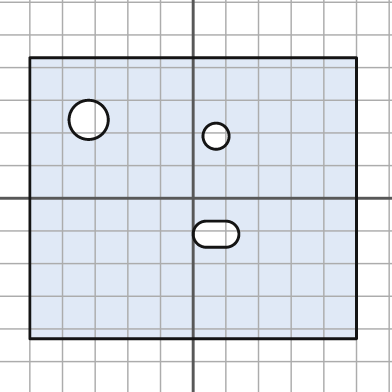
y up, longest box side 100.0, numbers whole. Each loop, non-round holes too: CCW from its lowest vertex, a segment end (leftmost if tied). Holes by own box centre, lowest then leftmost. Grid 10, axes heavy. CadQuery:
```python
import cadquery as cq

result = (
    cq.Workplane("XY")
    .moveTo(-50.0, -43.0)
    .lineTo(50.0, -43.0)
    .lineTo(50.0, 43.0)
    .lineTo(-50.0, 43.0)
    .close()
    .moveTo(4.0, -15.0)
    .lineTo(10.0, -15.0)
    .threePointArc((14.0, -11.0), (10.0, -7.0))
    .lineTo(4.0, -7.0)
    .threePointArc((0.0, -11.0), (4.0, -15.0))
    .close()
    .moveTo(7.0, 19.0)
    .circle(4.0)
    .moveTo(-32.0, 24.0)
    .circle(6.0)
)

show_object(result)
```